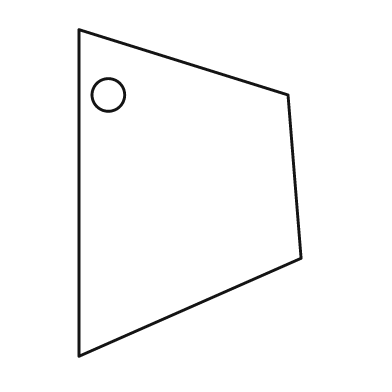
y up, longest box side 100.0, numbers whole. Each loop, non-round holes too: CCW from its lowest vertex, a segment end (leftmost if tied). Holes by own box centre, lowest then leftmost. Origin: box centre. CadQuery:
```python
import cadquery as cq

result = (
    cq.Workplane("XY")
    .moveTo(-34.0, -50.0)
    .lineTo(34.0, -20.0)
    .lineTo(30.0, 30.0)
    .lineTo(-34.0, 50.0)
    .close()
    .moveTo(-25.0, 30.0)
    .circle(5.0)
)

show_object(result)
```